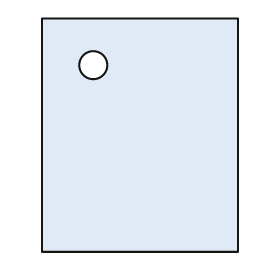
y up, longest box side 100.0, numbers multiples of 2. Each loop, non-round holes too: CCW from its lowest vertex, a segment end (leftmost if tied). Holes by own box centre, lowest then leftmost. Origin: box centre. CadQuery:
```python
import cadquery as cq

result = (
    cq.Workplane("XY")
    .moveTo(-42.0, -50.0)
    .lineTo(42.0, -50.0)
    .lineTo(42.0, 50.0)
    .lineTo(-42.0, 50.0)
    .close()
    .moveTo(-20.0, 30.0)
    .circle(6.0)
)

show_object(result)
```